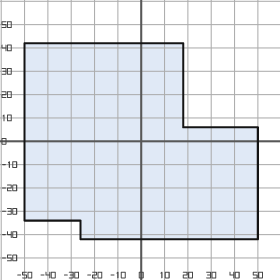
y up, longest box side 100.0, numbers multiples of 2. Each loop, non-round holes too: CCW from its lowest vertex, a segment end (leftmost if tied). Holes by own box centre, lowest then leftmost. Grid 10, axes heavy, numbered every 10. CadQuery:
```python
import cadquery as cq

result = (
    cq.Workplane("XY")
    .moveTo(-26.0, -42.0)
    .lineTo(50.0, -42.0)
    .lineTo(50.0, 6.0)
    .lineTo(18.0, 6.0)
    .lineTo(18.0, 42.0)
    .lineTo(-50.0, 42.0)
    .lineTo(-50.0, -34.0)
    .lineTo(-26.0, -34.0)
    .close()
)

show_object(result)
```